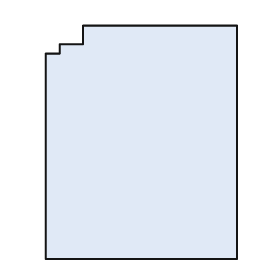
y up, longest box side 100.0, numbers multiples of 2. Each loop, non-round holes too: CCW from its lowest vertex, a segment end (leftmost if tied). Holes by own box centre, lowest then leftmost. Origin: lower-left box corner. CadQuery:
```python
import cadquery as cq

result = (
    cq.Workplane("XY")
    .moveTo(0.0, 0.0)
    .lineTo(82.0, 0.0)
    .lineTo(82.0, 100.0)
    .lineTo(16.0, 100.0)
    .lineTo(16.0, 92.0)
    .lineTo(6.0, 92.0)
    .lineTo(6.0, 88.0)
    .lineTo(0.0, 88.0)
    .close()
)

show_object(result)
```